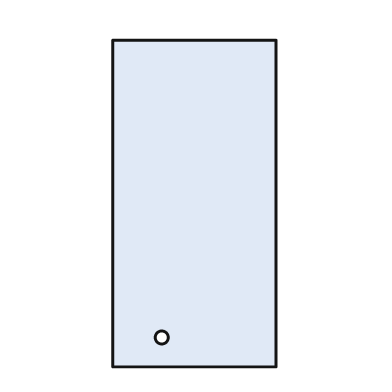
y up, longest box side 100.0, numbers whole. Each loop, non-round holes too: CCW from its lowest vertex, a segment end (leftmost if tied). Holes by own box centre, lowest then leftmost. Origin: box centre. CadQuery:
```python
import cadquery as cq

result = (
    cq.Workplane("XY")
    .moveTo(-25.0, -50.0)
    .lineTo(25.0, -50.0)
    .lineTo(25.0, 50.0)
    .lineTo(-25.0, 50.0)
    .close()
    .moveTo(-10.0, -41.0)
    .circle(2.0)
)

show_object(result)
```